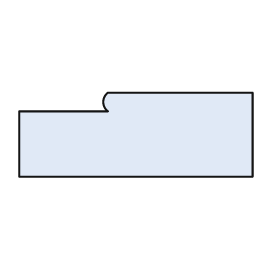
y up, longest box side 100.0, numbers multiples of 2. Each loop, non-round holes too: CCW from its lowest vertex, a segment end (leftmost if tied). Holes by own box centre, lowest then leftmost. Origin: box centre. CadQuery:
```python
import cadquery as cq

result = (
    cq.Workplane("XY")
    .moveTo(-50.0, -18.0)
    .lineTo(50.0, -18.0)
    .lineTo(50.0, 18.0)
    .lineTo(-12.0, 18.0)
    .threePointArc((-14.0, 14.0), (-12.0, 10.0))
    .lineTo(-50.0, 10.0)
    .close()
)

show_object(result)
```